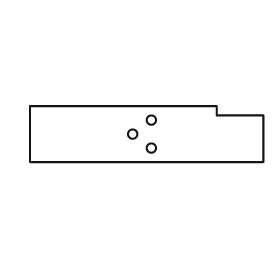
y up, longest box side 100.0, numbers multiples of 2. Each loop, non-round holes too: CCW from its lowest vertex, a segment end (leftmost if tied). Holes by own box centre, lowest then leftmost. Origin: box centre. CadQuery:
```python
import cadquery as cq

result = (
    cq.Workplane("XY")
    .moveTo(-50.0, -12.0)
    .lineTo(50.0, -12.0)
    .lineTo(50.0, 8.0)
    .lineTo(30.0, 8.0)
    .lineTo(30.0, 12.0)
    .lineTo(-50.0, 12.0)
    .close()
    .moveTo(2.0, -6.0)
    .circle(2.0)
    .moveTo(-6.0, 0.0)
    .circle(2.0)
    .moveTo(2.0, 6.0)
    .circle(2.0)
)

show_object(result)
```